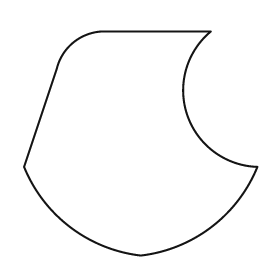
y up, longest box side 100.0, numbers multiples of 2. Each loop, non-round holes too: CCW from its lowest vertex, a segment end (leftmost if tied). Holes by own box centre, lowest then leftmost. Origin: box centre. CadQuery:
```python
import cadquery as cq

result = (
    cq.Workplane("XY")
    .moveTo(0.0, -48.0)
    .threePointArc((30.0, -36.0), (50.0, -10.0))
    .threePointArc((20.0, 12.0), (30.0, 48.0))
    .lineTo(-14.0, 48.0)
    .threePointArc((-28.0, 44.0), (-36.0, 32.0))
    .lineTo(-50.0, -10.0)
    .threePointArc((-30.0, -36.0), (0.0, -48.0))
    .close()
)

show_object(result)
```